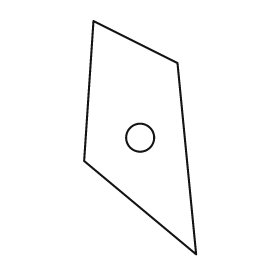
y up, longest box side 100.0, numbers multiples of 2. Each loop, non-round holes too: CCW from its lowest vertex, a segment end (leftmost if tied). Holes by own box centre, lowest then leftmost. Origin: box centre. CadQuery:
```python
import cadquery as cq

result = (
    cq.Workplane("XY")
    .moveTo(24.0, -50.0)
    .lineTo(16.0, 32.0)
    .lineTo(-20.0, 50.0)
    .lineTo(-24.0, -10.0)
    .close()
    .moveTo(0.0, 0.0)
    .circle(6.0)
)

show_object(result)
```